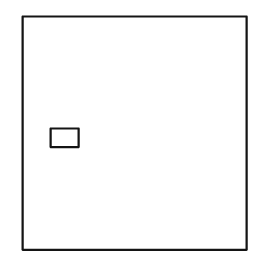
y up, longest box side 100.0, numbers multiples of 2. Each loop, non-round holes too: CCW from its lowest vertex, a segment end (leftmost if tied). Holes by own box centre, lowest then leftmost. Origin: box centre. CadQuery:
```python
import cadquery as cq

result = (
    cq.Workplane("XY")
    .moveTo(-48.0, -50.0)
    .lineTo(48.0, -50.0)
    .lineTo(48.0, 50.0)
    .lineTo(-48.0, 50.0)
    .close()
    .moveTo(-36.0, -6.0)
    .lineTo(-24.0, -6.0)
    .lineTo(-24.0, 2.0)
    .lineTo(-36.0, 2.0)
    .close()
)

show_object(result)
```